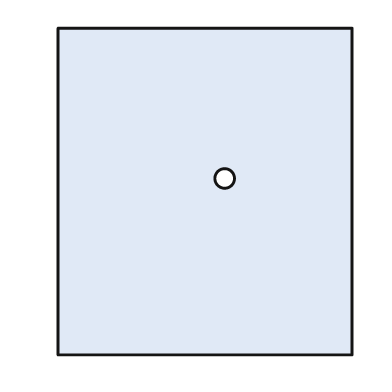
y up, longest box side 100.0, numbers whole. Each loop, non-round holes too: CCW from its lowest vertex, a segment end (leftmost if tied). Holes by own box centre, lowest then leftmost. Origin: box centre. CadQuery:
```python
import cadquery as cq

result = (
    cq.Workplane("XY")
    .moveTo(-45.0, -50.0)
    .lineTo(45.0, -50.0)
    .lineTo(45.0, 50.0)
    .lineTo(-45.0, 50.0)
    .close()
    .moveTo(6.0, 4.0)
    .circle(3.0)
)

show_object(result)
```